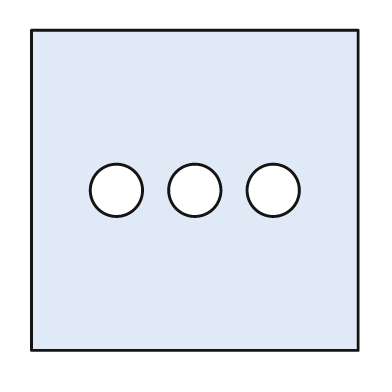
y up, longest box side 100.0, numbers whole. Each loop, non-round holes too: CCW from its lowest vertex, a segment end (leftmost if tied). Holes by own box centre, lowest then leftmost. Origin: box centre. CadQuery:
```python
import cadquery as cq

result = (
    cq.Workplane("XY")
    .moveTo(-50.0, -49.0)
    .lineTo(50.0, -49.0)
    .lineTo(50.0, 49.0)
    .lineTo(-50.0, 49.0)
    .close()
    .moveTo(-24.0, 0.0)
    .circle(8.0)
    .moveTo(0.0, 0.0)
    .circle(8.0)
    .moveTo(24.0, 0.0)
    .circle(8.0)
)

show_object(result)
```